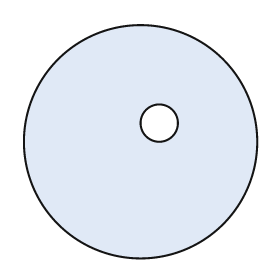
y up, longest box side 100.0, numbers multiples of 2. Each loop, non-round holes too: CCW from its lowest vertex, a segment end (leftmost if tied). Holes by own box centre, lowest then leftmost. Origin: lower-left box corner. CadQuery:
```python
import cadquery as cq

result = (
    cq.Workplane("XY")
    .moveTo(50.0, 50.0)
    .circle(50.0)
    .moveTo(58.0, 58.0)
    .circle(8.0)
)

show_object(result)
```